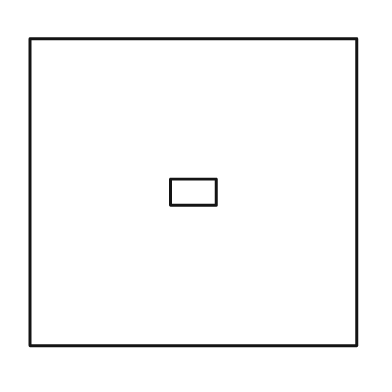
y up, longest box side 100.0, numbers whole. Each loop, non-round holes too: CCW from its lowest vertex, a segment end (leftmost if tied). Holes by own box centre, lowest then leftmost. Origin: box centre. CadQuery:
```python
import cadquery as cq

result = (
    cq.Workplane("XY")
    .moveTo(-50.0, -47.0)
    .lineTo(50.0, -47.0)
    .lineTo(50.0, 47.0)
    .lineTo(-50.0, 47.0)
    .close()
    .moveTo(-7.0, -4.0)
    .lineTo(7.0, -4.0)
    .lineTo(7.0, 4.0)
    .lineTo(-7.0, 4.0)
    .close()
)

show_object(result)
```